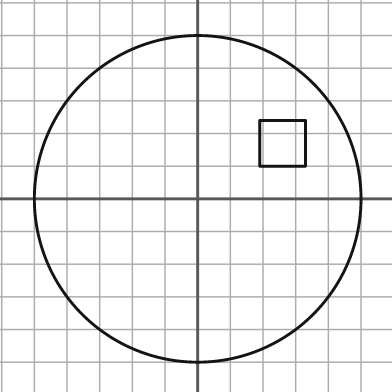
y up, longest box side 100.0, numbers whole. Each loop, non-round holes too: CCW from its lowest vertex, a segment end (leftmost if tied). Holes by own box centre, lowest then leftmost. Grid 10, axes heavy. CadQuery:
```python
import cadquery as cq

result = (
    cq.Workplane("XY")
    .moveTo(0.0, 0.0)
    .circle(50.0)
    .moveTo(19.0, 10.0)
    .lineTo(33.0, 10.0)
    .lineTo(33.0, 24.0)
    .lineTo(19.0, 24.0)
    .close()
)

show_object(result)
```